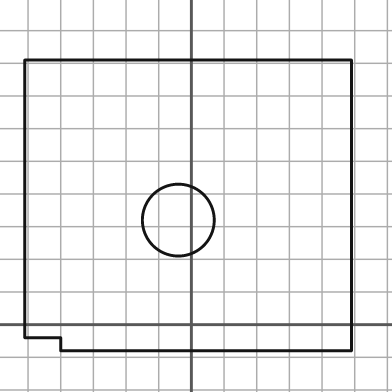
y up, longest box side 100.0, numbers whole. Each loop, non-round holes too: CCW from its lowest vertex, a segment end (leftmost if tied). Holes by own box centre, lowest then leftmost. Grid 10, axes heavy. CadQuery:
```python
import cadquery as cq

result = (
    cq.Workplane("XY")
    .moveTo(-40.0, -8.0)
    .lineTo(49.0, -8.0)
    .lineTo(49.0, 81.0)
    .lineTo(-51.0, 81.0)
    .lineTo(-51.0, -4.0)
    .lineTo(-40.0, -4.0)
    .close()
    .moveTo(-4.0, 32.0)
    .circle(11.0)
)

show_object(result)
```